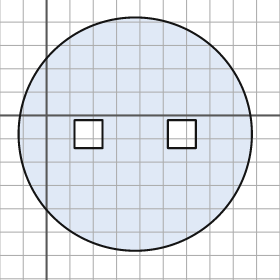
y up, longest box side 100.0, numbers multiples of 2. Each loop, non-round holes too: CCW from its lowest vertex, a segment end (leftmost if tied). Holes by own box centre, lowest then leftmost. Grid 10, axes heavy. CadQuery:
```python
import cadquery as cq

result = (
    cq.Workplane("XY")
    .moveTo(38.0, -8.0)
    .circle(50.0)
    .moveTo(12.0, -14.0)
    .lineTo(24.0, -14.0)
    .lineTo(24.0, -2.0)
    .lineTo(12.0, -2.0)
    .close()
    .moveTo(52.0, -14.0)
    .lineTo(64.0, -14.0)
    .lineTo(64.0, -2.0)
    .lineTo(52.0, -2.0)
    .close()
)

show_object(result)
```